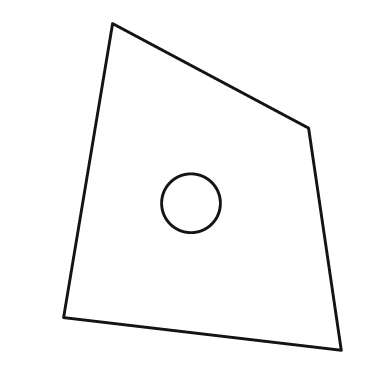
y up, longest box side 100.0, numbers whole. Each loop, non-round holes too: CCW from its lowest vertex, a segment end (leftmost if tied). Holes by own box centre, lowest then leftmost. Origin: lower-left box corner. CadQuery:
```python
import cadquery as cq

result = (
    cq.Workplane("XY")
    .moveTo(85.0, 0.0)
    .lineTo(75.0, 68.0)
    .lineTo(15.0, 100.0)
    .lineTo(0.0, 10.0)
    .close()
    .moveTo(39.0, 45.0)
    .circle(9.0)
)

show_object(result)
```